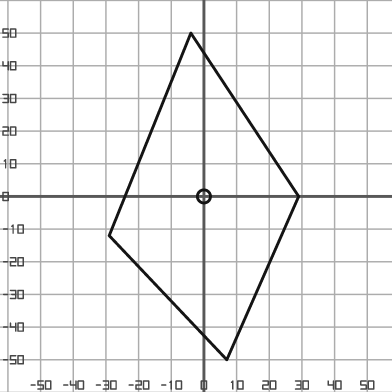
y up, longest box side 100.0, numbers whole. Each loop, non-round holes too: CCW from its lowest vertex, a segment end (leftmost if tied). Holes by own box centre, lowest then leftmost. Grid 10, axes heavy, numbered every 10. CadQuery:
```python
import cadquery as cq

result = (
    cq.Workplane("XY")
    .moveTo(7.0, -50.0)
    .lineTo(29.0, 0.0)
    .lineTo(-4.0, 50.0)
    .lineTo(-29.0, -12.0)
    .close()
    .moveTo(0.0, 0.0)
    .circle(2.0)
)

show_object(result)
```